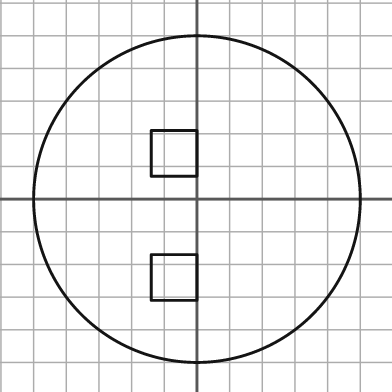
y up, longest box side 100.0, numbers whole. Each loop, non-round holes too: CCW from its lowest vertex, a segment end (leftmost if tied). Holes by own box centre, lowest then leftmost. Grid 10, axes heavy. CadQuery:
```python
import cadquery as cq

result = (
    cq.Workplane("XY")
    .moveTo(0.0, 0.0)
    .circle(50.0)
    .moveTo(-14.0, -31.0)
    .lineTo(0.0, -31.0)
    .lineTo(0.0, -17.0)
    .lineTo(-14.0, -17.0)
    .close()
    .moveTo(-14.0, 7.0)
    .lineTo(0.0, 7.0)
    .lineTo(0.0, 21.0)
    .lineTo(-14.0, 21.0)
    .close()
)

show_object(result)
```